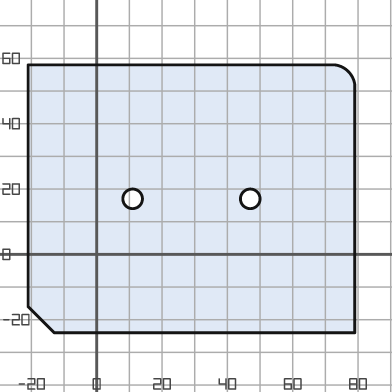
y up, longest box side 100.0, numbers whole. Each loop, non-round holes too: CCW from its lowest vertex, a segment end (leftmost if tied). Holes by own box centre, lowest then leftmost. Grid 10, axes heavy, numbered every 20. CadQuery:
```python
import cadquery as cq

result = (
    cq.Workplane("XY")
    .moveTo(-13.0, -24.0)
    .lineTo(79.0, -24.0)
    .lineTo(79.0, 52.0)
    .threePointArc((77.0, 56.0), (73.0, 58.0))
    .lineTo(-21.0, 58.0)
    .lineTo(-21.0, -16.0)
    .close()
    .moveTo(11.0, 17.0)
    .circle(3.0)
    .moveTo(47.0, 17.0)
    .circle(3.0)
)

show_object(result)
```